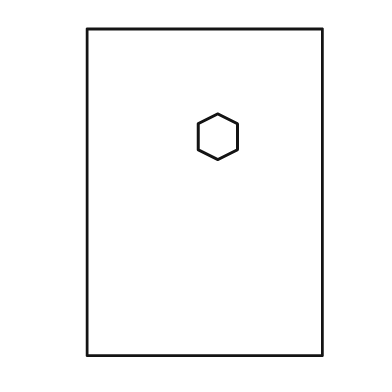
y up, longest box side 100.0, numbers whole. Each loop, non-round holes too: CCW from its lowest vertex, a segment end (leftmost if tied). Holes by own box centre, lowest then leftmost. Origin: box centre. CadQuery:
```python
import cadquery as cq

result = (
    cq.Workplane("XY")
    .moveTo(-36.0, -50.0)
    .lineTo(36.0, -50.0)
    .lineTo(36.0, 50.0)
    .lineTo(-36.0, 50.0)
    .close()
    .moveTo(4.0, 10.0)
    .lineTo(10.0, 13.0)
    .lineTo(10.0, 21.0)
    .lineTo(4.0, 24.0)
    .lineTo(-2.0, 21.0)
    .lineTo(-2.0, 13.0)
    .close()
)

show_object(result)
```